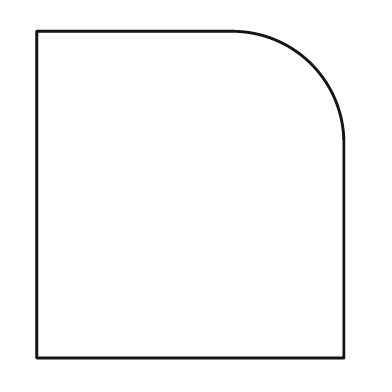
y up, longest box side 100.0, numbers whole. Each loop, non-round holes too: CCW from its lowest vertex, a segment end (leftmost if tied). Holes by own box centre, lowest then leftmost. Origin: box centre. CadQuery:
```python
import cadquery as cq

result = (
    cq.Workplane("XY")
    .moveTo(-47.0, -50.0)
    .lineTo(47.0, -50.0)
    .lineTo(47.0, 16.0)
    .threePointArc((37.0, 40.0), (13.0, 50.0))
    .lineTo(-47.0, 50.0)
    .close()
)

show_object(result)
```